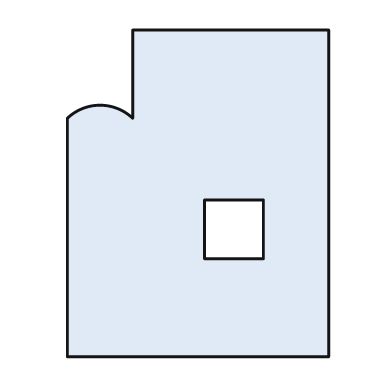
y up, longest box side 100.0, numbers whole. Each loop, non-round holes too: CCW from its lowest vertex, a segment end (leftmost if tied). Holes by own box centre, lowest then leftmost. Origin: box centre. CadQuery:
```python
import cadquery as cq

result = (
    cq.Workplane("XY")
    .moveTo(-40.0, -50.0)
    .lineTo(40.0, -50.0)
    .lineTo(40.0, 50.0)
    .lineTo(-20.0, 50.0)
    .lineTo(-20.0, 23.0)
    .threePointArc((-30.0, 27.0), (-40.0, 23.0))
    .close()
    .moveTo(2.0, -20.0)
    .lineTo(20.0, -20.0)
    .lineTo(20.0, -2.0)
    .lineTo(2.0, -2.0)
    .close()
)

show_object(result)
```